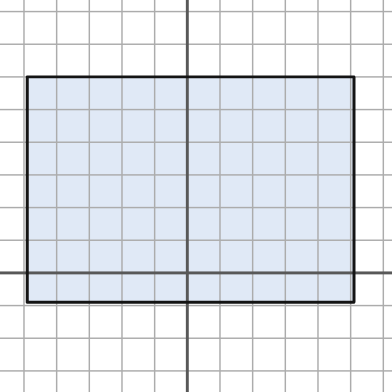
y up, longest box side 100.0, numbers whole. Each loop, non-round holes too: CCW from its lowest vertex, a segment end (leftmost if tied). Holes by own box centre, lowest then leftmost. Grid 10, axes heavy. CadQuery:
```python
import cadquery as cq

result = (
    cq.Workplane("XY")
    .moveTo(-49.0, -9.0)
    .lineTo(51.0, -9.0)
    .lineTo(51.0, 60.0)
    .lineTo(-49.0, 60.0)
    .close()
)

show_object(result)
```